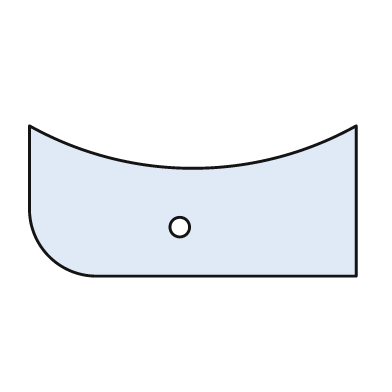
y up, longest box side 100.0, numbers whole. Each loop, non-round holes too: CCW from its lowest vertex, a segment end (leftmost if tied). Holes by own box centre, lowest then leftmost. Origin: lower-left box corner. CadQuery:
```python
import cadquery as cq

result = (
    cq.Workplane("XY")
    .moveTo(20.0, 0.0)
    .lineTo(100.0, 0.0)
    .lineTo(100.0, 46.0)
    .threePointArc((50.0, 33.0), (0.0, 46.0))
    .lineTo(0.0, 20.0)
    .threePointArc((6.0, 6.0), (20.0, 0.0))
    .close()
    .moveTo(46.0, 15.0)
    .circle(3.0)
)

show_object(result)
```